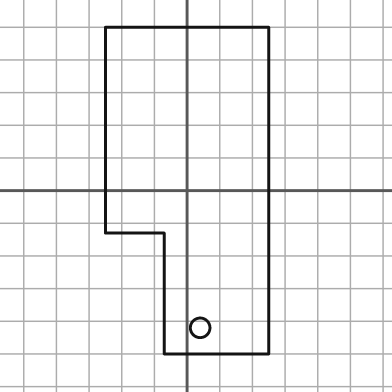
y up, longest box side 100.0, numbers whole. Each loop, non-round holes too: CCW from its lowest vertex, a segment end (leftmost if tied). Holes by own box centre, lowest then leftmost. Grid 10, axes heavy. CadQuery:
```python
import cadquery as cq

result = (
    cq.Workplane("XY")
    .moveTo(-7.0, -50.0)
    .lineTo(25.0, -50.0)
    .lineTo(25.0, 50.0)
    .lineTo(-25.0, 50.0)
    .lineTo(-25.0, -13.0)
    .lineTo(-7.0, -13.0)
    .close()
    .moveTo(4.0, -42.0)
    .circle(3.0)
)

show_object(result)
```